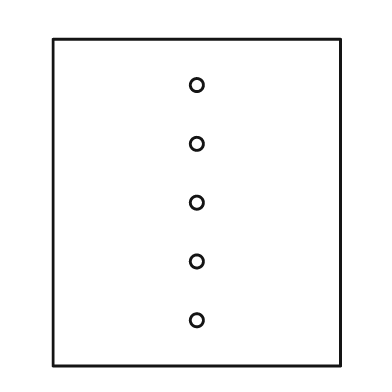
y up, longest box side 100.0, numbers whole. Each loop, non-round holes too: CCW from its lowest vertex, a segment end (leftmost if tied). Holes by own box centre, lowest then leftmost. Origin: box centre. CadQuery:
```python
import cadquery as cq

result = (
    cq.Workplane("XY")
    .moveTo(-44.0, -50.0)
    .lineTo(44.0, -50.0)
    .lineTo(44.0, 50.0)
    .lineTo(-44.0, 50.0)
    .close()
    .moveTo(0.0, -36.0)
    .circle(2.0)
    .moveTo(0.0, -18.0)
    .circle(2.0)
    .moveTo(0.0, 0.0)
    .circle(2.0)
    .moveTo(0.0, 18.0)
    .circle(2.0)
    .moveTo(0.0, 36.0)
    .circle(2.0)
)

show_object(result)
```